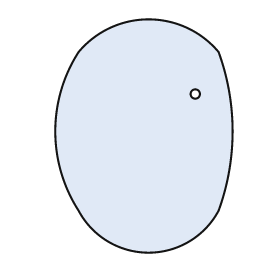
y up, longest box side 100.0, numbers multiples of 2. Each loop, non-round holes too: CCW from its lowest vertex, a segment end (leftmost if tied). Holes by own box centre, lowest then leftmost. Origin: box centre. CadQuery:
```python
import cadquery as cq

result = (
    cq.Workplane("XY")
    .moveTo(-28.0, -32.0)
    .threePointArc((2.0, -50.0), (32.0, -32.0))
    .threePointArc((38.0, 2.0), (32.0, 36.0))
    .threePointArc((2.0, 50.0), (-28.0, 36.0))
    .threePointArc((-38.0, 2.0), (-28.0, -32.0))
    .close()
    .moveTo(22.0, 18.0)
    .circle(2.0)
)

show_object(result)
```